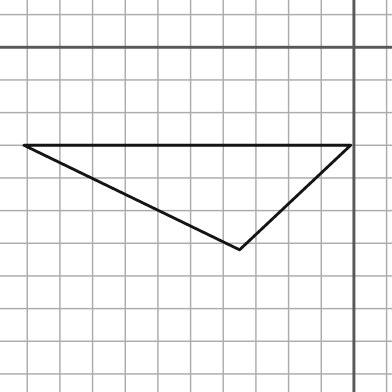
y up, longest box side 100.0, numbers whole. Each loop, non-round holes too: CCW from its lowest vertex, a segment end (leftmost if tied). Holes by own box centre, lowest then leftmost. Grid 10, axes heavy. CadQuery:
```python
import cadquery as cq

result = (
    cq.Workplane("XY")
    .moveTo(-35.0, -62.0)
    .lineTo(-1.0, -30.0)
    .lineTo(-101.0, -30.0)
    .close()
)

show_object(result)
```